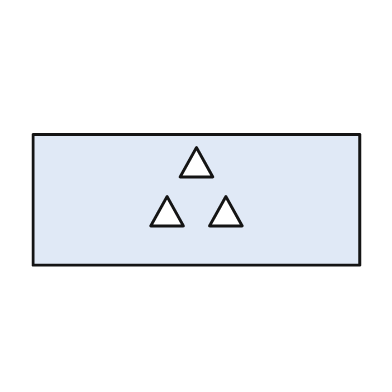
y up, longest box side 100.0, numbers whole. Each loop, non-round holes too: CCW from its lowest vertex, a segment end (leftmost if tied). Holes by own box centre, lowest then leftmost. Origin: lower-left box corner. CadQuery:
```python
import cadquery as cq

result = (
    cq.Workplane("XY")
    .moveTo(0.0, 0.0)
    .lineTo(100.0, 0.0)
    .lineTo(100.0, 40.0)
    .lineTo(0.0, 40.0)
    .close()
    .moveTo(36.0, 12.0)
    .lineTo(46.0, 12.0)
    .lineTo(41.0, 21.0)
    .close()
    .moveTo(54.0, 12.0)
    .lineTo(64.0, 12.0)
    .lineTo(59.0, 21.0)
    .close()
    .moveTo(45.0, 27.0)
    .lineTo(55.0, 27.0)
    .lineTo(50.0, 36.0)
    .close()
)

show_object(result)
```